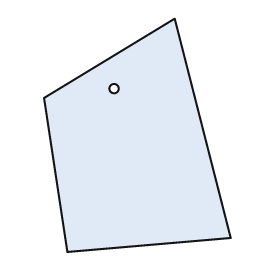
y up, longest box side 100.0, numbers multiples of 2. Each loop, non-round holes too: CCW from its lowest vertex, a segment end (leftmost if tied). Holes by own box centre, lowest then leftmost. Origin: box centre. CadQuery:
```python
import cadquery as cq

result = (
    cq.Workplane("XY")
    .moveTo(-30.0, -50.0)
    .lineTo(40.0, -44.0)
    .lineTo(16.0, 50.0)
    .lineTo(-40.0, 16.0)
    .close()
    .moveTo(-10.0, 20.0)
    .circle(2.0)
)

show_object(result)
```